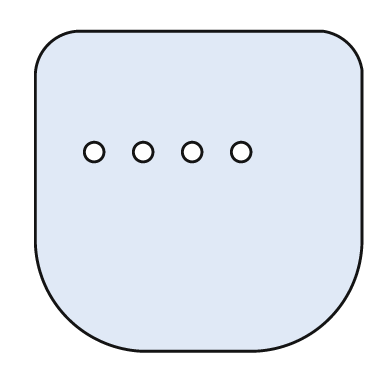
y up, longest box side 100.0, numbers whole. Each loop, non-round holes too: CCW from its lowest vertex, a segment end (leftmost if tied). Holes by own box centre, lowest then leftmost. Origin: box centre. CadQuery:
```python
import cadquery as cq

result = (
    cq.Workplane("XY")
    .moveTo(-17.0, -49.0)
    .lineTo(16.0, -49.0)
    .threePointArc((40.0, -39.0), (50.0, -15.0))
    .lineTo(50.0, 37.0)
    .threePointArc((46.0, 45.0), (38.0, 49.0))
    .lineTo(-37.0, 49.0)
    .threePointArc((-46.0, 45.0), (-50.0, 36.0))
    .lineTo(-50.0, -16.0)
    .threePointArc((-40.0, -39.0), (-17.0, -49.0))
    .close()
    .moveTo(-32.0, 12.0)
    .circle(3.0)
    .moveTo(-17.0, 12.0)
    .circle(3.0)
    .moveTo(-2.0, 12.0)
    .circle(3.0)
    .moveTo(13.0, 12.0)
    .circle(3.0)
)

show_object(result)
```